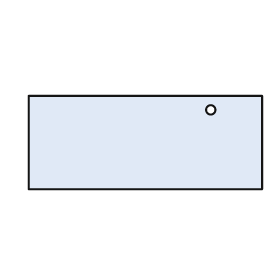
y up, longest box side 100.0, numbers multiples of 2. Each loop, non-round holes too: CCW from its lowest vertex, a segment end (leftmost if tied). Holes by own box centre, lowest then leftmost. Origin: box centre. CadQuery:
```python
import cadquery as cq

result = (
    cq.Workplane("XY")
    .moveTo(-50.0, -20.0)
    .lineTo(50.0, -20.0)
    .lineTo(50.0, 20.0)
    .lineTo(-50.0, 20.0)
    .close()
    .moveTo(28.0, 14.0)
    .circle(2.0)
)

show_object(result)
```